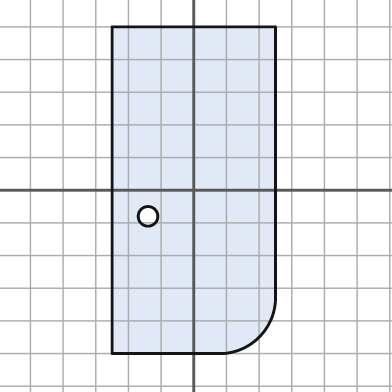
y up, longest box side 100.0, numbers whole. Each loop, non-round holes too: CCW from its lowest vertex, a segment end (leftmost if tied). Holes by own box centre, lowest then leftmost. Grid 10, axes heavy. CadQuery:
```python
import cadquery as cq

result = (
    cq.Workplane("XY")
    .moveTo(-25.0, -50.0)
    .lineTo(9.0, -50.0)
    .threePointArc((20.0, -45.0), (25.0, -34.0))
    .lineTo(25.0, 50.0)
    .lineTo(-25.0, 50.0)
    .close()
    .moveTo(-14.0, -8.0)
    .circle(3.0)
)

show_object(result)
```